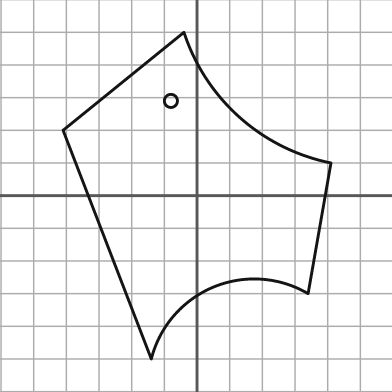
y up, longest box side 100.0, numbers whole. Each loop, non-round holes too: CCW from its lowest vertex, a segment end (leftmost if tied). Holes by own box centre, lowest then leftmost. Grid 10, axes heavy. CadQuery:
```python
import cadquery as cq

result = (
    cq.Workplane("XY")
    .moveTo(-14.0, -50.0)
    .threePointArc((5.0, -28.0), (34.0, -30.0))
    .lineTo(41.0, 10.0)
    .threePointArc((13.0, 24.0), (-4.0, 50.0))
    .lineTo(-41.0, 20.0)
    .close()
    .moveTo(-8.0, 29.0)
    .circle(2.0)
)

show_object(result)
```